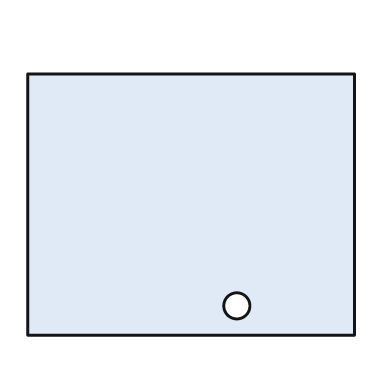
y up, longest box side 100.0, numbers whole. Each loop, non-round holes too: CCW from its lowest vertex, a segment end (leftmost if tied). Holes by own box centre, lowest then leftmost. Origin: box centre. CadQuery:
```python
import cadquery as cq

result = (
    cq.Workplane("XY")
    .moveTo(-50.0, -40.0)
    .lineTo(50.0, -40.0)
    .lineTo(50.0, 40.0)
    .lineTo(-50.0, 40.0)
    .close()
    .moveTo(14.0, -31.0)
    .circle(4.0)
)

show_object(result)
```